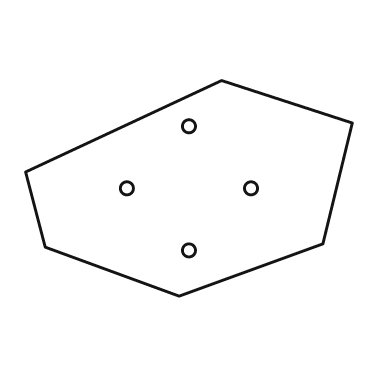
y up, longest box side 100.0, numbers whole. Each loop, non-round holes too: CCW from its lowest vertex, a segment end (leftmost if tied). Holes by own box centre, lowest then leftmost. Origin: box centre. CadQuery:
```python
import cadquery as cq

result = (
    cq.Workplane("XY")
    .moveTo(-3.0, -33.0)
    .lineTo(41.0, -17.0)
    .lineTo(50.0, 20.0)
    .lineTo(10.0, 33.0)
    .lineTo(-50.0, 5.0)
    .lineTo(-44.0, -18.0)
    .close()
    .moveTo(0.0, -19.0)
    .circle(2.0)
    .moveTo(-19.0, 0.0)
    .circle(2.0)
    .moveTo(19.0, 0.0)
    .circle(2.0)
    .moveTo(0.0, 19.0)
    .circle(2.0)
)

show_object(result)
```